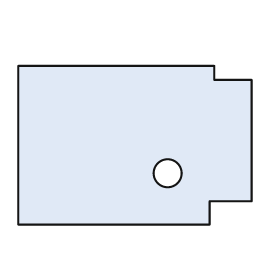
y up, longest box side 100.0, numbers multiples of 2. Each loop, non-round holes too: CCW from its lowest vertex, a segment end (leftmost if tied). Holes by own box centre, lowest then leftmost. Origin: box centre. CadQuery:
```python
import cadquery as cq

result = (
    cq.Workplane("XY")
    .moveTo(-50.0, -34.0)
    .lineTo(32.0, -34.0)
    .lineTo(32.0, -24.0)
    .lineTo(50.0, -24.0)
    .lineTo(50.0, 28.0)
    .lineTo(34.0, 28.0)
    .lineTo(34.0, 34.0)
    .lineTo(-50.0, 34.0)
    .close()
    .moveTo(14.0, -12.0)
    .circle(6.0)
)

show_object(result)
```